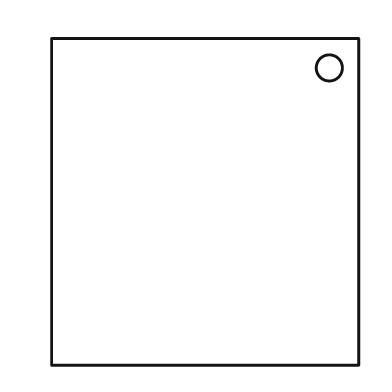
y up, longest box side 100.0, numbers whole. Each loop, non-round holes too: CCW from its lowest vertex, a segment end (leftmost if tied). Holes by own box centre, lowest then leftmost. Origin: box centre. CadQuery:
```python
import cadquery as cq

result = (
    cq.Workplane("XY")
    .moveTo(-47.0, -50.0)
    .lineTo(47.0, -50.0)
    .lineTo(47.0, 50.0)
    .lineTo(-47.0, 50.0)
    .close()
    .moveTo(38.0, 41.0)
    .circle(4.0)
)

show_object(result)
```